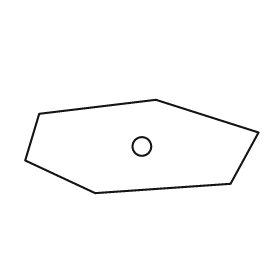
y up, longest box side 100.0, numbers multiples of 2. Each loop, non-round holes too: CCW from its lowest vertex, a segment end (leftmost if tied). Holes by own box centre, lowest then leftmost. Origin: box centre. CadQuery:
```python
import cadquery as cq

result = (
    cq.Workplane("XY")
    .moveTo(-20.0, -20.0)
    .lineTo(38.0, -16.0)
    .lineTo(50.0, 6.0)
    .lineTo(6.0, 20.0)
    .lineTo(-44.0, 14.0)
    .lineTo(-50.0, -6.0)
    .close()
    .moveTo(0.0, 0.0)
    .circle(4.0)
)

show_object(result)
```